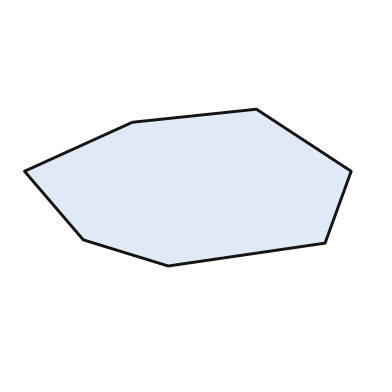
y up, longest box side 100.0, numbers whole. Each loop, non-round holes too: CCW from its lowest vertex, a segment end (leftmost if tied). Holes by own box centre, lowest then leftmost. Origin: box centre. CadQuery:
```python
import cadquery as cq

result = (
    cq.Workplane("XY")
    .moveTo(-6.0, -24.0)
    .lineTo(42.0, -17.0)
    .lineTo(50.0, 5.0)
    .lineTo(21.0, 24.0)
    .lineTo(-17.0, 20.0)
    .lineTo(-50.0, 5.0)
    .lineTo(-32.0, -16.0)
    .close()
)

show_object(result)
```